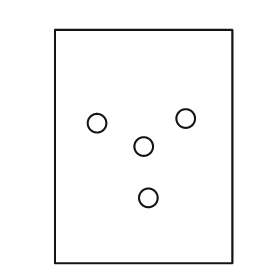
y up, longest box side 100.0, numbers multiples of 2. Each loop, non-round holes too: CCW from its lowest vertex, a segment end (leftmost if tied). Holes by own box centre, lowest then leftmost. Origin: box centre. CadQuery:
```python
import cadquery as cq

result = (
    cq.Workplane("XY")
    .moveTo(-38.0, -50.0)
    .lineTo(38.0, -50.0)
    .lineTo(38.0, 50.0)
    .lineTo(-38.0, 50.0)
    .close()
    .moveTo(2.0, -22.0)
    .circle(4.0)
    .moveTo(0.0, 0.0)
    .circle(4.0)
    .moveTo(-20.0, 10.0)
    .circle(4.0)
    .moveTo(18.0, 12.0)
    .circle(4.0)
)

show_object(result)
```